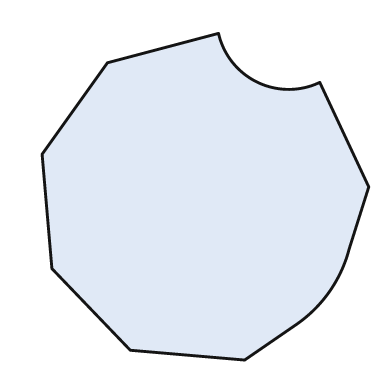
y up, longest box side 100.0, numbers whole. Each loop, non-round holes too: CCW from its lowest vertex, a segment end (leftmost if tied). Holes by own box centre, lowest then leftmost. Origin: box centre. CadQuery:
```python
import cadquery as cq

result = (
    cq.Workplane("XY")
    .moveTo(12.0, -50.0)
    .lineTo(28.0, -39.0)
    .threePointArc((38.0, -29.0), (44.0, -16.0))
    .lineTo(50.0, 3.0)
    .lineTo(35.0, 35.0)
    .threePointArc((16.0, 35.0), (4.0, 50.0))
    .lineTo(-30.0, 41.0)
    .lineTo(-50.0, 13.0)
    .lineTo(-47.0, -22.0)
    .lineTo(-23.0, -47.0)
    .close()
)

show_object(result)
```